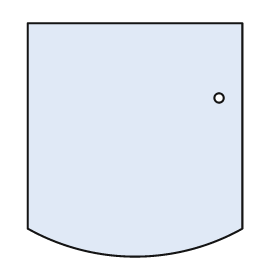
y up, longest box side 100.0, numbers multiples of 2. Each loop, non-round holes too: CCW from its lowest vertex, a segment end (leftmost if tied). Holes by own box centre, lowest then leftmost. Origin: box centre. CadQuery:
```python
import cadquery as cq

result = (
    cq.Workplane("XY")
    .moveTo(-46.0, -38.0)
    .threePointArc((0.0, -50.0), (46.0, -38.0))
    .lineTo(46.0, 50.0)
    .lineTo(-46.0, 50.0)
    .close()
    .moveTo(36.0, 18.0)
    .circle(2.0)
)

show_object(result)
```